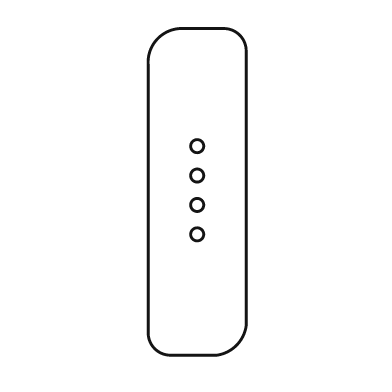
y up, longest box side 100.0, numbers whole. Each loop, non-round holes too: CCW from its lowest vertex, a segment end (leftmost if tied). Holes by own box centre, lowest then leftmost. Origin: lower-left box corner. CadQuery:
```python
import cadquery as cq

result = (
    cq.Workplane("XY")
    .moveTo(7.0, 0.0)
    .lineTo(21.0, 0.0)
    .threePointArc((27.0, 3.0), (30.0, 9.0))
    .lineTo(30.0, 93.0)
    .threePointArc((28.0, 98.0), (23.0, 100.0))
    .lineTo(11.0, 100.0)
    .threePointArc((3.0, 97.0), (0.0, 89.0))
    .lineTo(0.0, 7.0)
    .threePointArc((2.0, 2.0), (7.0, 0.0))
    .close()
    .moveTo(15.0, 37.0)
    .circle(2.0)
    .moveTo(15.0, 46.0)
    .circle(2.0)
    .moveTo(15.0, 55.0)
    .circle(2.0)
    .moveTo(15.0, 64.0)
    .circle(2.0)
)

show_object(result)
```